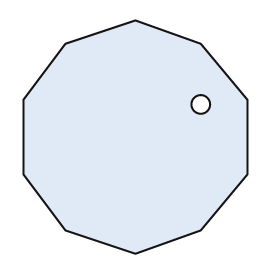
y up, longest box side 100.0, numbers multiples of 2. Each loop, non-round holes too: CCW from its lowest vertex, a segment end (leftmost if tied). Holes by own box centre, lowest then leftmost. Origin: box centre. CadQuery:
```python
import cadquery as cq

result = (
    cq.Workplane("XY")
    .moveTo(0.0, -50.0)
    .lineTo(28.0, -40.0)
    .lineTo(48.0, -16.0)
    .lineTo(48.0, 16.0)
    .lineTo(28.0, 40.0)
    .lineTo(0.0, 50.0)
    .lineTo(-30.0, 40.0)
    .lineTo(-48.0, 16.0)
    .lineTo(-48.0, -16.0)
    .lineTo(-30.0, -40.0)
    .close()
    .moveTo(28.0, 14.0)
    .circle(4.0)
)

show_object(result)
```